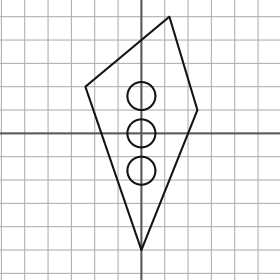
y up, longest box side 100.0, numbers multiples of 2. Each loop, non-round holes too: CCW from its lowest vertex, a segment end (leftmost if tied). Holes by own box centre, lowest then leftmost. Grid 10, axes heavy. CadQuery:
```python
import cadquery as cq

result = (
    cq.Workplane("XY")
    .moveTo(0.0, -50.0)
    .lineTo(24.0, 10.0)
    .lineTo(12.0, 50.0)
    .lineTo(-24.0, 20.0)
    .close()
    .moveTo(0.0, -16.0)
    .circle(6.0)
    .moveTo(0.0, 0.0)
    .circle(6.0)
    .moveTo(0.0, 16.0)
    .circle(6.0)
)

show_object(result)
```